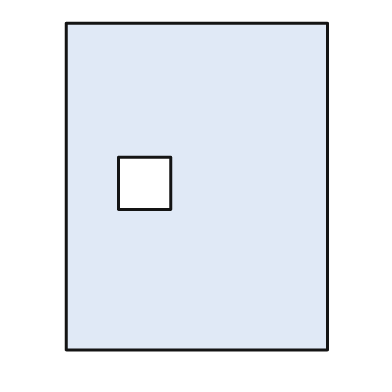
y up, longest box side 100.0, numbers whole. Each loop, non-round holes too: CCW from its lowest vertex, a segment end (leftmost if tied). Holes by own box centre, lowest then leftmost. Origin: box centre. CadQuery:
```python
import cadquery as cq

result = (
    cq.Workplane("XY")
    .moveTo(-40.0, -50.0)
    .lineTo(40.0, -50.0)
    .lineTo(40.0, 50.0)
    .lineTo(-40.0, 50.0)
    .close()
    .moveTo(-24.0, -7.0)
    .lineTo(-8.0, -7.0)
    .lineTo(-8.0, 9.0)
    .lineTo(-24.0, 9.0)
    .close()
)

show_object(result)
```